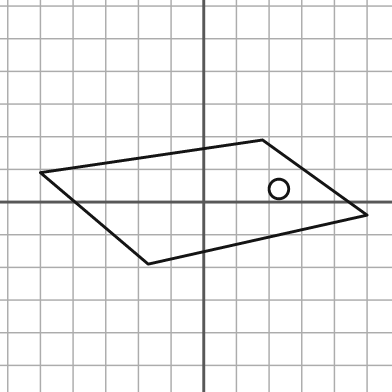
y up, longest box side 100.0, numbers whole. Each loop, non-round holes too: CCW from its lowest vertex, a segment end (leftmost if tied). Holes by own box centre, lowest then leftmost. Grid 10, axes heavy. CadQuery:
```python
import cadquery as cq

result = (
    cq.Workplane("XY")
    .moveTo(-17.0, -19.0)
    .lineTo(50.0, -4.0)
    .lineTo(18.0, 19.0)
    .lineTo(-50.0, 9.0)
    .close()
    .moveTo(23.0, 4.0)
    .circle(3.0)
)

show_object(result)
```